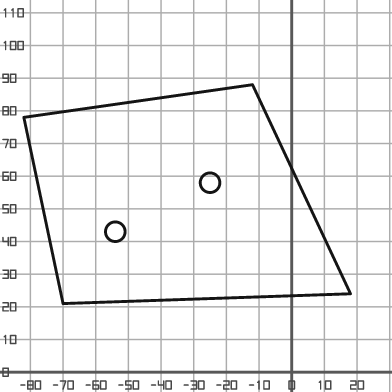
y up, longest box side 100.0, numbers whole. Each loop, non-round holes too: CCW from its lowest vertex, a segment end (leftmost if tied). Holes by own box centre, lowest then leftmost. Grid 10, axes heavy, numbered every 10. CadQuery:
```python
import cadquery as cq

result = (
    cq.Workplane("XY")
    .moveTo(-70.0, 21.0)
    .lineTo(18.0, 24.0)
    .lineTo(-12.0, 88.0)
    .lineTo(-82.0, 78.0)
    .close()
    .moveTo(-54.0, 43.0)
    .circle(3.0)
    .moveTo(-25.0, 58.0)
    .circle(3.0)
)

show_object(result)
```